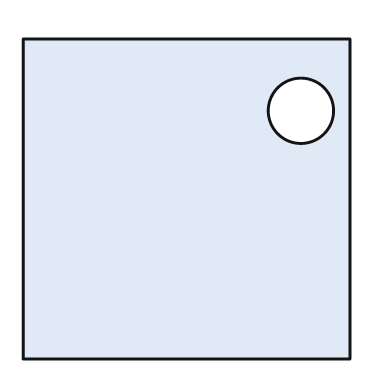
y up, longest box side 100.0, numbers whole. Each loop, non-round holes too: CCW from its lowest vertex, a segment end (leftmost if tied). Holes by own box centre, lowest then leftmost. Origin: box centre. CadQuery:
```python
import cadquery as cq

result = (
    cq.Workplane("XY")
    .moveTo(-50.0, -49.0)
    .lineTo(50.0, -49.0)
    .lineTo(50.0, 49.0)
    .lineTo(-50.0, 49.0)
    .close()
    .moveTo(35.0, 27.0)
    .circle(10.0)
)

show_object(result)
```